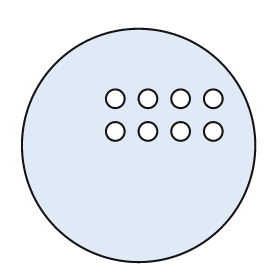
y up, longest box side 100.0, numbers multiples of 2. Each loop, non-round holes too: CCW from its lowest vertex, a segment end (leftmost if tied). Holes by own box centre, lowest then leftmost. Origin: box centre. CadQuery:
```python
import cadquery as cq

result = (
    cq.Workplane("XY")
    .moveTo(0.0, 0.0)
    .circle(50.0)
    .moveTo(-10.0, 6.0)
    .circle(4.0)
    .moveTo(4.0, 6.0)
    .circle(4.0)
    .moveTo(18.0, 6.0)
    .circle(4.0)
    .moveTo(32.0, 6.0)
    .circle(4.0)
    .moveTo(-10.0, 20.0)
    .circle(4.0)
    .moveTo(4.0, 20.0)
    .circle(4.0)
    .moveTo(18.0, 20.0)
    .circle(4.0)
    .moveTo(32.0, 20.0)
    .circle(4.0)
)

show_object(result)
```